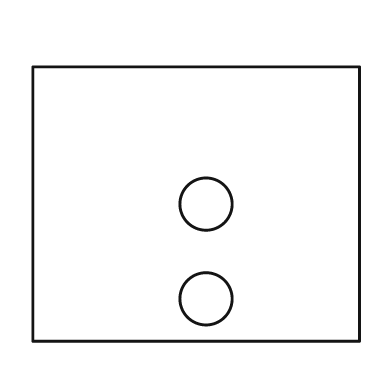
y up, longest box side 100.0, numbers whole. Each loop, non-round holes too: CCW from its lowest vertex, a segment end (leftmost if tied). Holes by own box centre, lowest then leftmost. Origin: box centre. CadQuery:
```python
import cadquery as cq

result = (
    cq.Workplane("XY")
    .moveTo(-50.0, -42.0)
    .lineTo(50.0, -42.0)
    .lineTo(50.0, 42.0)
    .lineTo(-50.0, 42.0)
    .close()
    .moveTo(3.0, -29.0)
    .circle(8.0)
    .moveTo(3.0, 0.0)
    .circle(8.0)
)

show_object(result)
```